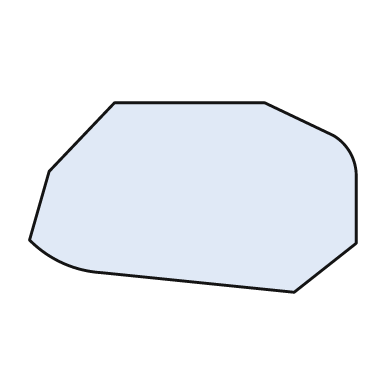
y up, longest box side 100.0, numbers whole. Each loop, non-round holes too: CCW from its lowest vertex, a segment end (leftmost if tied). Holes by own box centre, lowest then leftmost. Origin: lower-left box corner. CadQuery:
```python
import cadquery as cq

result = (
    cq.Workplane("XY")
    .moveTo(81.0, 0.0)
    .lineTo(100.0, 15.0)
    .lineTo(100.0, 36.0)
    .threePointArc((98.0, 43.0), (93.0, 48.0))
    .lineTo(72.0, 58.0)
    .lineTo(26.0, 58.0)
    .lineTo(6.0, 37.0)
    .lineTo(0.0, 16.0)
    .threePointArc((10.0, 9.0), (22.0, 6.0))
    .close()
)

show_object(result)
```